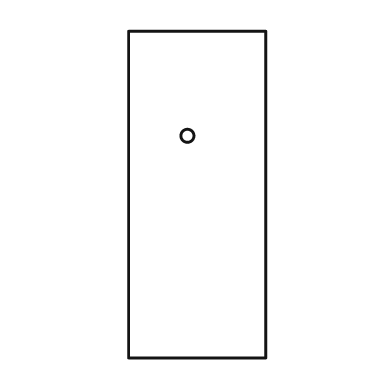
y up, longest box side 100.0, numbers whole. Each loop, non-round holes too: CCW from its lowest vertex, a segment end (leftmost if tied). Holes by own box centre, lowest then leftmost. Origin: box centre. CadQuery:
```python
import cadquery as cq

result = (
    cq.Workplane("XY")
    .moveTo(-21.0, -50.0)
    .lineTo(21.0, -50.0)
    .lineTo(21.0, 50.0)
    .lineTo(-21.0, 50.0)
    .close()
    .moveTo(-3.0, 18.0)
    .circle(2.0)
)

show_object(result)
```